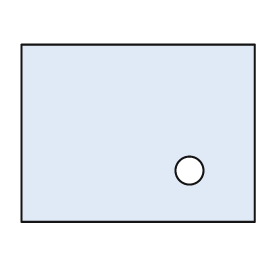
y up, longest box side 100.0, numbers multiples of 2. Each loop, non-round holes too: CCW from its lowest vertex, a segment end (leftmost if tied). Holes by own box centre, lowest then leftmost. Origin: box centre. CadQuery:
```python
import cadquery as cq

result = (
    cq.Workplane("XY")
    .moveTo(-50.0, -38.0)
    .lineTo(50.0, -38.0)
    .lineTo(50.0, 38.0)
    .lineTo(-50.0, 38.0)
    .close()
    .moveTo(22.0, -16.0)
    .circle(6.0)
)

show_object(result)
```